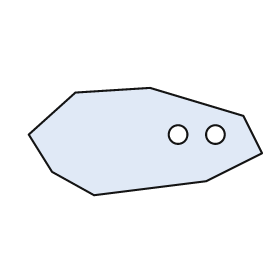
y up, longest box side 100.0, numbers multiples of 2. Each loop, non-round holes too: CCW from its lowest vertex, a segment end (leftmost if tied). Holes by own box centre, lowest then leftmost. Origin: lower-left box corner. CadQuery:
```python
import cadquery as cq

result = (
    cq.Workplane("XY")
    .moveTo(28.0, 0.0)
    .lineTo(76.0, 6.0)
    .lineTo(100.0, 18.0)
    .lineTo(92.0, 34.0)
    .lineTo(52.0, 46.0)
    .lineTo(20.0, 44.0)
    .lineTo(0.0, 26.0)
    .lineTo(10.0, 10.0)
    .close()
    .moveTo(64.0, 26.0)
    .circle(4.0)
    .moveTo(80.0, 26.0)
    .circle(4.0)
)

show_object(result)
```